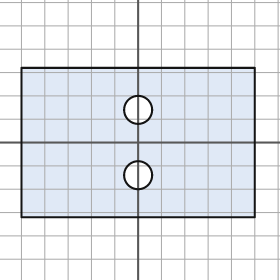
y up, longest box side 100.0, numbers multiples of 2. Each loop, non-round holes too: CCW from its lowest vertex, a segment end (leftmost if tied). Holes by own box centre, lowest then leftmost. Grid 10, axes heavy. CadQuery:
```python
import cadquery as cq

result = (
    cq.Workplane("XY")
    .moveTo(-50.0, -32.0)
    .lineTo(50.0, -32.0)
    .lineTo(50.0, 32.0)
    .lineTo(-50.0, 32.0)
    .close()
    .moveTo(0.0, -14.0)
    .circle(6.0)
    .moveTo(0.0, 14.0)
    .circle(6.0)
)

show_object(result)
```